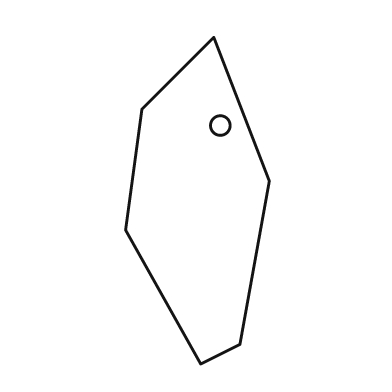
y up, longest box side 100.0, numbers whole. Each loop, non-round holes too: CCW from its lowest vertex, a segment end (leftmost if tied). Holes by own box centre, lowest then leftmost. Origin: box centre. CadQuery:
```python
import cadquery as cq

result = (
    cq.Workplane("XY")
    .moveTo(1.0, -50.0)
    .lineTo(13.0, -44.0)
    .lineTo(22.0, 6.0)
    .lineTo(5.0, 50.0)
    .lineTo(-17.0, 28.0)
    .lineTo(-22.0, -9.0)
    .close()
    .moveTo(7.0, 23.0)
    .circle(3.0)
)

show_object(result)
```